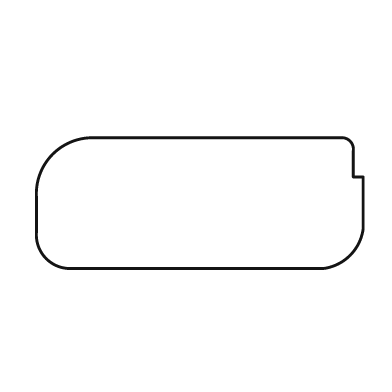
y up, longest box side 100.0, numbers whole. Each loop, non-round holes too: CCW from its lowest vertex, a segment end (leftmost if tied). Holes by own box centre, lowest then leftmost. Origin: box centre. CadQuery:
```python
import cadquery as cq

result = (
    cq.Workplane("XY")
    .moveTo(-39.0, -20.0)
    .lineTo(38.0, -20.0)
    .threePointArc((46.0, -16.0), (50.0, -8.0))
    .lineTo(50.0, 8.0)
    .lineTo(47.0, 8.0)
    .lineTo(47.0, 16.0)
    .threePointArc((46.0, 19.0), (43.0, 20.0))
    .lineTo(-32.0, 20.0)
    .threePointArc((-45.0, 15.0), (-50.0, 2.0))
    .lineTo(-50.0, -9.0)
    .threePointArc((-47.0, -17.0), (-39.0, -20.0))
    .close()
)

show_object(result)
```